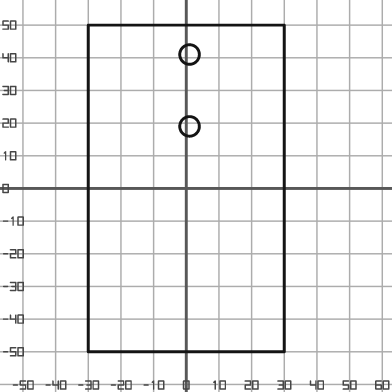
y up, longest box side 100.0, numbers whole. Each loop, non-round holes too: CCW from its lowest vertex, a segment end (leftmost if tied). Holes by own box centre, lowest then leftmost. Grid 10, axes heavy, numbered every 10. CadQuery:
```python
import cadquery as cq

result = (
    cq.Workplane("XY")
    .moveTo(-30.0, -50.0)
    .lineTo(30.0, -50.0)
    .lineTo(30.0, 50.0)
    .lineTo(-30.0, 50.0)
    .close()
    .moveTo(1.0, 19.0)
    .circle(3.0)
    .moveTo(1.0, 41.0)
    .circle(3.0)
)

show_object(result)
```